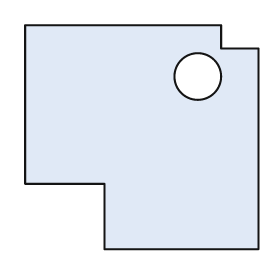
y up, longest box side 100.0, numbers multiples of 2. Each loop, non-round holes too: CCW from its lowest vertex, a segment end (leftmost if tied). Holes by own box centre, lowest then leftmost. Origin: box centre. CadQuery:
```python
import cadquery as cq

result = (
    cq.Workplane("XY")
    .moveTo(-16.0, -48.0)
    .lineTo(50.0, -48.0)
    .lineTo(50.0, 38.0)
    .lineTo(34.0, 38.0)
    .lineTo(34.0, 48.0)
    .lineTo(-50.0, 48.0)
    .lineTo(-50.0, -20.0)
    .lineTo(-16.0, -20.0)
    .close()
    .moveTo(24.0, 26.0)
    .circle(10.0)
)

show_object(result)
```